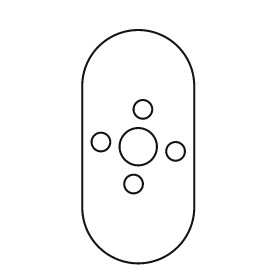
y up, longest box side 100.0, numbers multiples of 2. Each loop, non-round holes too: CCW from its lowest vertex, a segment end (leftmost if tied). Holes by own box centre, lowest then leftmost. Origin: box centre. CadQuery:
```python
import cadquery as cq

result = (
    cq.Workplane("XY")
    .moveTo(-24.0, -26.0)
    .threePointArc((0.0, -50.0), (24.0, -26.0))
    .lineTo(24.0, 26.0)
    .threePointArc((0.0, 50.0), (-24.0, 26.0))
    .close()
    .moveTo(-2.0, -16.0)
    .circle(4.0)
    .moveTo(16.0, -2.0)
    .circle(4.0)
    .moveTo(0.0, 0.0)
    .circle(8.0)
    .moveTo(-16.0, 2.0)
    .circle(4.0)
    .moveTo(2.0, 16.0)
    .circle(4.0)
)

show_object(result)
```